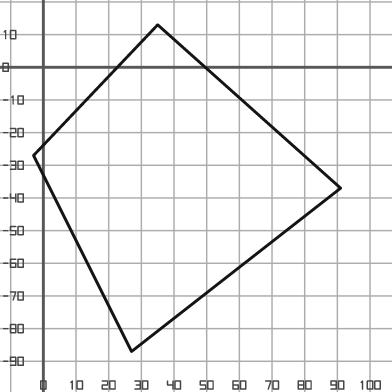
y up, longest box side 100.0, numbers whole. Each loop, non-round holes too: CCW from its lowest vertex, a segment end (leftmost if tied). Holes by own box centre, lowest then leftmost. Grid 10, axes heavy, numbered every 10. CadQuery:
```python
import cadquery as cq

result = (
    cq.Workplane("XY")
    .moveTo(27.0, -87.0)
    .lineTo(91.0, -37.0)
    .lineTo(35.0, 13.0)
    .lineTo(-3.0, -27.0)
    .close()
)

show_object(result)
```